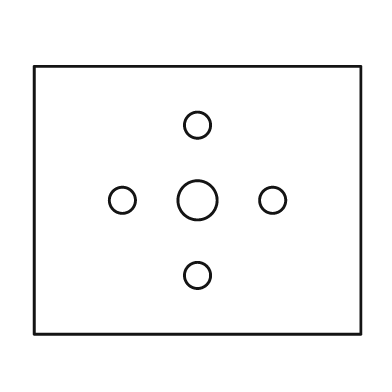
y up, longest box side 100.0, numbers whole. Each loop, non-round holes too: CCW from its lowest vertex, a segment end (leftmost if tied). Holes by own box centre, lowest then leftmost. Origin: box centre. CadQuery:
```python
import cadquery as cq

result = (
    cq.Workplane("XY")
    .moveTo(-50.0, -41.0)
    .lineTo(50.0, -41.0)
    .lineTo(50.0, 41.0)
    .lineTo(-50.0, 41.0)
    .close()
    .moveTo(0.0, -23.0)
    .circle(4.0)
    .moveTo(-23.0, 0.0)
    .circle(4.0)
    .moveTo(0.0, 0.0)
    .circle(6.0)
    .moveTo(23.0, 0.0)
    .circle(4.0)
    .moveTo(0.0, 23.0)
    .circle(4.0)
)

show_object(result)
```